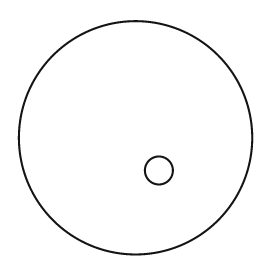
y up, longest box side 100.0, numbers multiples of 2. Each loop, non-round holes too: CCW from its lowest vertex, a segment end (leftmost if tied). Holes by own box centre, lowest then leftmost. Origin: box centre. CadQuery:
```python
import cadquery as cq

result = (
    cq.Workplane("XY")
    .moveTo(0.0, 0.0)
    .circle(50.0)
    .moveTo(10.0, -14.0)
    .circle(6.0)
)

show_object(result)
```